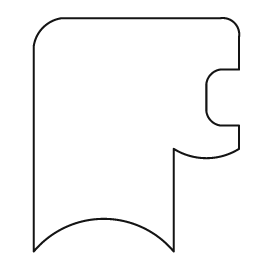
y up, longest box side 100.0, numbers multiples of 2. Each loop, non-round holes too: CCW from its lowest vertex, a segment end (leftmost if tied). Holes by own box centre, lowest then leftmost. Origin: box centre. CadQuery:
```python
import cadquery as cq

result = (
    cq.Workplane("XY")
    .moveTo(-44.0, -50.0)
    .threePointArc((-14.0, -36.0), (16.0, -50.0))
    .lineTo(16.0, -6.0)
    .threePointArc((30.0, -10.0), (44.0, -6.0))
    .lineTo(44.0, 4.0)
    .lineTo(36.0, 4.0)
    .threePointArc((32.0, 6.0), (30.0, 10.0))
    .lineTo(30.0, 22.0)
    .threePointArc((32.0, 26.0), (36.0, 28.0))
    .lineTo(44.0, 28.0)
    .lineTo(44.0, 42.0)
    .threePointArc((42.0, 48.0), (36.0, 50.0))
    .lineTo(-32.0, 50.0)
    .threePointArc((-40.0, 46.0), (-44.0, 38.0))
    .close()
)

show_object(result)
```